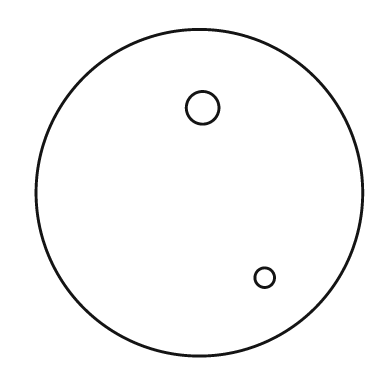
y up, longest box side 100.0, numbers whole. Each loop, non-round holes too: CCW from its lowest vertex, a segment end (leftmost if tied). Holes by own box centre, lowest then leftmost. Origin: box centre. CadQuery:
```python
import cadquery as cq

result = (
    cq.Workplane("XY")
    .moveTo(0.0, 0.0)
    .circle(50.0)
    .moveTo(20.0, -26.0)
    .circle(3.0)
    .moveTo(1.0, 26.0)
    .circle(5.0)
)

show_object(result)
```